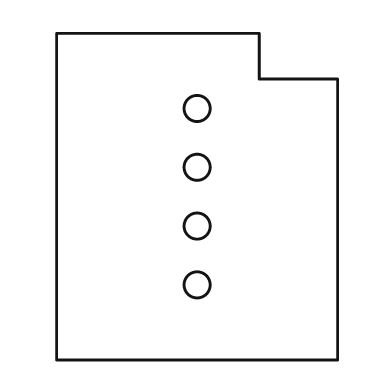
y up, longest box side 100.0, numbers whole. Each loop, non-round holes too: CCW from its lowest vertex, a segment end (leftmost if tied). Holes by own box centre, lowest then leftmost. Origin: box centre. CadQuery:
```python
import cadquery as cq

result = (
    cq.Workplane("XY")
    .moveTo(-43.0, -50.0)
    .lineTo(43.0, -50.0)
    .lineTo(43.0, 36.0)
    .lineTo(19.0, 36.0)
    .lineTo(19.0, 50.0)
    .lineTo(-43.0, 50.0)
    .close()
    .moveTo(0.0, -27.0)
    .circle(4.0)
    .moveTo(0.0, -9.0)
    .circle(4.0)
    .moveTo(0.0, 9.0)
    .circle(4.0)
    .moveTo(0.0, 27.0)
    .circle(4.0)
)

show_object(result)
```